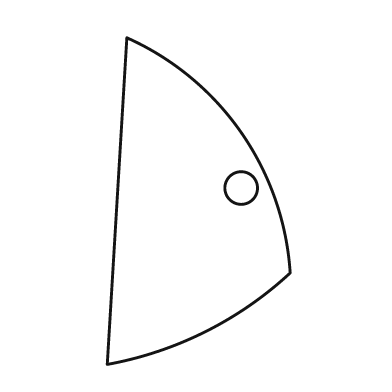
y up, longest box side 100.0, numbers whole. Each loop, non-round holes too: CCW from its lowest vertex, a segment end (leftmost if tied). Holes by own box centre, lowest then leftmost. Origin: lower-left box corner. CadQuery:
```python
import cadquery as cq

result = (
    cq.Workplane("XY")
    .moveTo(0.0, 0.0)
    .threePointArc((30.0, 10.0), (56.0, 28.0))
    .threePointArc((41.0, 71.0), (6.0, 100.0))
    .close()
    .moveTo(41.0, 54.0)
    .circle(5.0)
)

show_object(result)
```